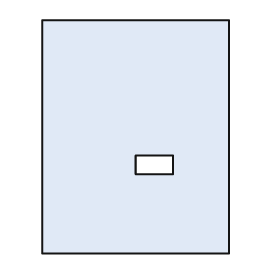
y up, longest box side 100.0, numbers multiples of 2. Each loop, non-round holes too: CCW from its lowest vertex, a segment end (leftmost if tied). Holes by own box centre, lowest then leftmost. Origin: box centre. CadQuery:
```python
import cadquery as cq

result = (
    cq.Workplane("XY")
    .moveTo(-40.0, -50.0)
    .lineTo(40.0, -50.0)
    .lineTo(40.0, 50.0)
    .lineTo(-40.0, 50.0)
    .close()
    .moveTo(0.0, -16.0)
    .lineTo(16.0, -16.0)
    .lineTo(16.0, -8.0)
    .lineTo(0.0, -8.0)
    .close()
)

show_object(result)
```